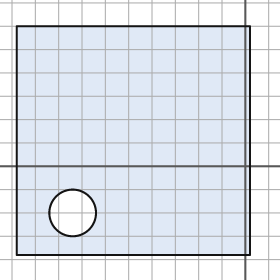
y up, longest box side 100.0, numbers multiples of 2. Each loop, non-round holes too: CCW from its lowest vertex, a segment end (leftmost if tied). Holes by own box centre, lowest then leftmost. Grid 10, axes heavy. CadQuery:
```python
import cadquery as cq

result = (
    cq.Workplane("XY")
    .moveTo(-98.0, -38.0)
    .lineTo(2.0, -38.0)
    .lineTo(2.0, 60.0)
    .lineTo(-98.0, 60.0)
    .close()
    .moveTo(-74.0, -20.0)
    .circle(10.0)
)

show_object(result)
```